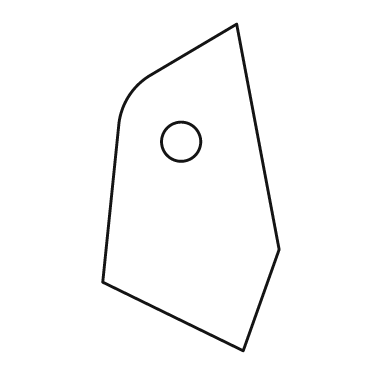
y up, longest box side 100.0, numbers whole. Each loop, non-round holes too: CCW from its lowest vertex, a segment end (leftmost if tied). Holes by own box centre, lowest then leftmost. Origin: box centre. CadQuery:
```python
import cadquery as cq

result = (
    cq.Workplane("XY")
    .moveTo(16.0, -50.0)
    .lineTo(27.0, -19.0)
    .lineTo(14.0, 50.0)
    .lineTo(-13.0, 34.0)
    .threePointArc((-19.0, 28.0), (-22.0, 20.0))
    .lineTo(-27.0, -29.0)
    .close()
    .moveTo(-3.0, 14.0)
    .circle(6.0)
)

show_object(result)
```